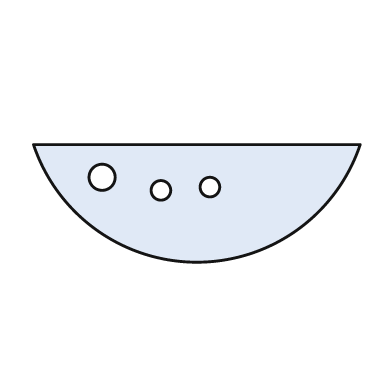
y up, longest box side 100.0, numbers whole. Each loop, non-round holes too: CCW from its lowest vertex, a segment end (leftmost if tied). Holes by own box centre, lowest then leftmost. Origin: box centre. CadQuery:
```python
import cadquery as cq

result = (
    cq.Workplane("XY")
    .moveTo(-50.0, 18.0)
    .threePointArc((0.0, -18.0), (50.0, 18.0))
    .close()
    .moveTo(-11.0, 4.0)
    .circle(3.0)
    .moveTo(4.0, 5.0)
    .circle(3.0)
    .moveTo(-29.0, 8.0)
    .circle(4.0)
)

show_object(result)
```